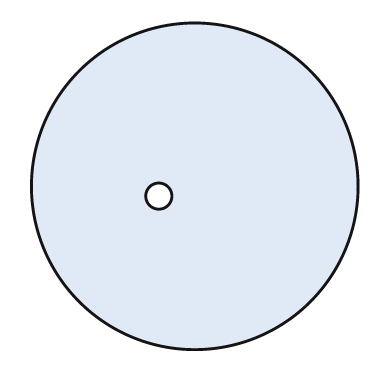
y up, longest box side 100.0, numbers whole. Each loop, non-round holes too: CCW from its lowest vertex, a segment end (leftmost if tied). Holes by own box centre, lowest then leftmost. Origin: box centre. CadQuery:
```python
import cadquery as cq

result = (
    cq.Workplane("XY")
    .moveTo(0.0, 0.0)
    .circle(50.0)
    .moveTo(-11.0, -3.0)
    .circle(4.0)
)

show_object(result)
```